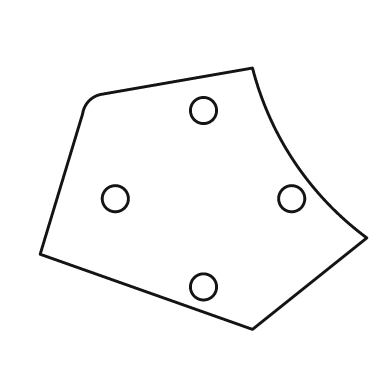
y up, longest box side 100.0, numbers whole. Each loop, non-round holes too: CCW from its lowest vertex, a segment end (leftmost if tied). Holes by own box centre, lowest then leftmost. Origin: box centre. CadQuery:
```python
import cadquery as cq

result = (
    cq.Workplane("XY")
    .moveTo(15.0, -40.0)
    .lineTo(50.0, -12.0)
    .threePointArc((28.0, 11.0), (15.0, 40.0))
    .lineTo(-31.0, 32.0)
    .threePointArc((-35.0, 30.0), (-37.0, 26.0))
    .lineTo(-50.0, -17.0)
    .close()
    .moveTo(0.0, -27.0)
    .circle(4.0)
    .moveTo(-27.0, 0.0)
    .circle(4.0)
    .moveTo(27.0, 0.0)
    .circle(4.0)
    .moveTo(0.0, 27.0)
    .circle(4.0)
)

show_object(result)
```